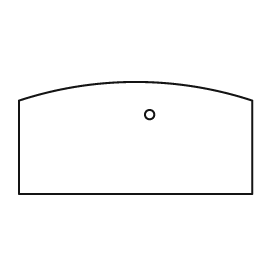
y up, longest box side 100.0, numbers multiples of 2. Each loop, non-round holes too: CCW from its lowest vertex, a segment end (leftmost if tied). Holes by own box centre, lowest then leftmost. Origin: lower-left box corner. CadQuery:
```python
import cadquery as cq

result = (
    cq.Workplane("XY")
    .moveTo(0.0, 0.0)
    .lineTo(100.0, 0.0)
    .lineTo(100.0, 40.0)
    .threePointArc((50.0, 48.0), (0.0, 40.0))
    .close()
    .moveTo(56.0, 34.0)
    .circle(2.0)
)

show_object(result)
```